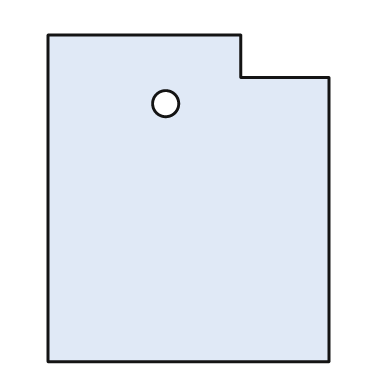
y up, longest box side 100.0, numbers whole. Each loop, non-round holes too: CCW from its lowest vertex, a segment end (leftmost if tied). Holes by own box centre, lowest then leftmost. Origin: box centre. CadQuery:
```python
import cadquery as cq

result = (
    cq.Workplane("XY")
    .moveTo(-43.0, -50.0)
    .lineTo(43.0, -50.0)
    .lineTo(43.0, 37.0)
    .lineTo(16.0, 37.0)
    .lineTo(16.0, 50.0)
    .lineTo(-43.0, 50.0)
    .close()
    .moveTo(-7.0, 29.0)
    .circle(4.0)
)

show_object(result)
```